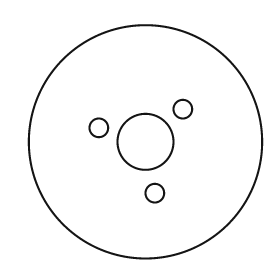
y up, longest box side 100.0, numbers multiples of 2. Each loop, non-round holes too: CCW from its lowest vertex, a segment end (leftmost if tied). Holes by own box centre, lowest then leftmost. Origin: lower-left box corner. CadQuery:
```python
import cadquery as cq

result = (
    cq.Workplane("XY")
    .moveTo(50.0, 50.0)
    .circle(50.0)
    .moveTo(54.0, 28.0)
    .circle(4.0)
    .moveTo(50.0, 50.0)
    .circle(12.0)
    .moveTo(30.0, 56.0)
    .circle(4.0)
    .moveTo(66.0, 64.0)
    .circle(4.0)
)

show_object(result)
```